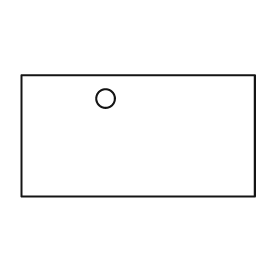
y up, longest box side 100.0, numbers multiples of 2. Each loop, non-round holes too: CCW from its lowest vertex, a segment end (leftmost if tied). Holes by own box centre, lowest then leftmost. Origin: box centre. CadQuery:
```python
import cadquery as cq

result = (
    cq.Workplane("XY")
    .moveTo(-50.0, -26.0)
    .lineTo(50.0, -26.0)
    .lineTo(50.0, 26.0)
    .lineTo(-50.0, 26.0)
    .close()
    .moveTo(-14.0, 16.0)
    .circle(4.0)
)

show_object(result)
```